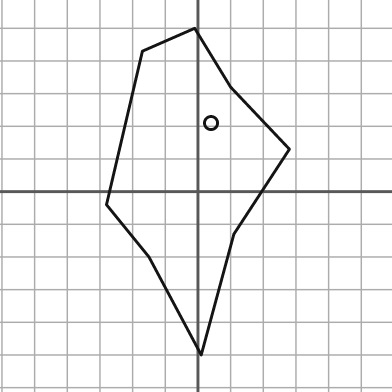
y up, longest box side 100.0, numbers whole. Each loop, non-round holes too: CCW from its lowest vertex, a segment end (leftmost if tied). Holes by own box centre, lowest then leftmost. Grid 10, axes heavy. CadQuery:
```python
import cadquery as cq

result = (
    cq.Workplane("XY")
    .moveTo(1.0, -50.0)
    .lineTo(11.0, -13.0)
    .lineTo(28.0, 13.0)
    .lineTo(10.0, 32.0)
    .lineTo(-1.0, 50.0)
    .lineTo(-17.0, 43.0)
    .lineTo(-28.0, -4.0)
    .lineTo(-15.0, -20.0)
    .close()
    .moveTo(4.0, 21.0)
    .circle(2.0)
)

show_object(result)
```